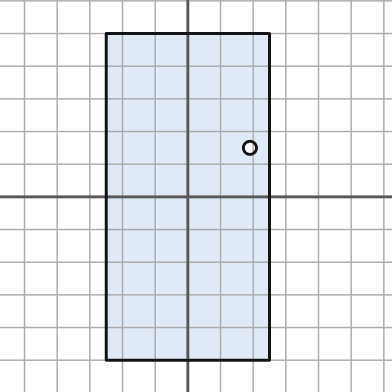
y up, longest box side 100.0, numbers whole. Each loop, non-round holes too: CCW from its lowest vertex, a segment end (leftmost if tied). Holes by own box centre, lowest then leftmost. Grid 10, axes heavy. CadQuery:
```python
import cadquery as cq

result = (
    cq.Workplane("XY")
    .moveTo(-25.0, -50.0)
    .lineTo(25.0, -50.0)
    .lineTo(25.0, 50.0)
    .lineTo(-25.0, 50.0)
    .close()
    .moveTo(19.0, 15.0)
    .circle(2.0)
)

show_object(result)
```